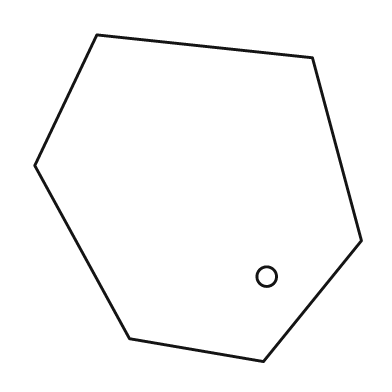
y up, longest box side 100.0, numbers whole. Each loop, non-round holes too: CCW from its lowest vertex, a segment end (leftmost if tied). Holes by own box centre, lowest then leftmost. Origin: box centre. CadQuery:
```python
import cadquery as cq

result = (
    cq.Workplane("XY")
    .moveTo(20.0, -50.0)
    .lineTo(50.0, -13.0)
    .lineTo(35.0, 43.0)
    .lineTo(-31.0, 50.0)
    .lineTo(-50.0, 10.0)
    .lineTo(-21.0, -43.0)
    .close()
    .moveTo(21.0, -24.0)
    .circle(3.0)
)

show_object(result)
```